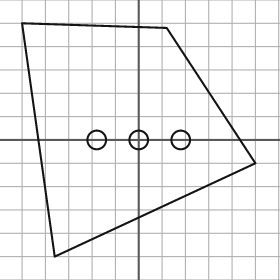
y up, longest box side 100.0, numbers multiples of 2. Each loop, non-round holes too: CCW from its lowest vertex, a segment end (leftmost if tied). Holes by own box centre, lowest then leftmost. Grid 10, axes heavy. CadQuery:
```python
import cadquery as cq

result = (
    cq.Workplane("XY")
    .moveTo(-36.0, -50.0)
    .lineTo(50.0, -10.0)
    .lineTo(12.0, 48.0)
    .lineTo(-50.0, 50.0)
    .close()
    .moveTo(-18.0, 0.0)
    .circle(4.0)
    .moveTo(0.0, 0.0)
    .circle(4.0)
    .moveTo(18.0, 0.0)
    .circle(4.0)
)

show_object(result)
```